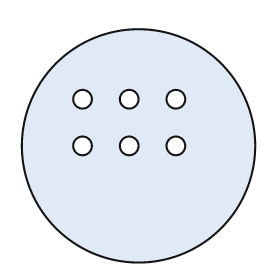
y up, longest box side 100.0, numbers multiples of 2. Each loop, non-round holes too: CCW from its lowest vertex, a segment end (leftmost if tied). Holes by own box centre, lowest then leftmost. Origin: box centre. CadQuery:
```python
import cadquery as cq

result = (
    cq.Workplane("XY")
    .moveTo(0.0, 0.0)
    .circle(50.0)
    .moveTo(-24.0, 0.0)
    .circle(4.0)
    .moveTo(-4.0, 0.0)
    .circle(4.0)
    .moveTo(16.0, 0.0)
    .circle(4.0)
    .moveTo(-24.0, 20.0)
    .circle(4.0)
    .moveTo(-4.0, 20.0)
    .circle(4.0)
    .moveTo(16.0, 20.0)
    .circle(4.0)
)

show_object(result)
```